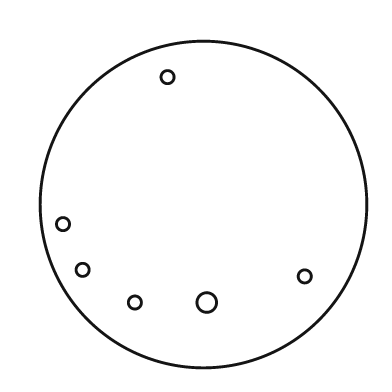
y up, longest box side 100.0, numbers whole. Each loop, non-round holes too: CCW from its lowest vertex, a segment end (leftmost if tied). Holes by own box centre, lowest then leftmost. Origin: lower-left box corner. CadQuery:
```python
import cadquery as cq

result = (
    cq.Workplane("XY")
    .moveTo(50.0, 50.0)
    .circle(50.0)
    .moveTo(29.0, 20.0)
    .circle(2.0)
    .moveTo(51.0, 20.0)
    .circle(3.0)
    .moveTo(81.0, 28.0)
    .circle(2.0)
    .moveTo(13.0, 30.0)
    .circle(2.0)
    .moveTo(7.0, 44.0)
    .circle(2.0)
    .moveTo(39.0, 89.0)
    .circle(2.0)
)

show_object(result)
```